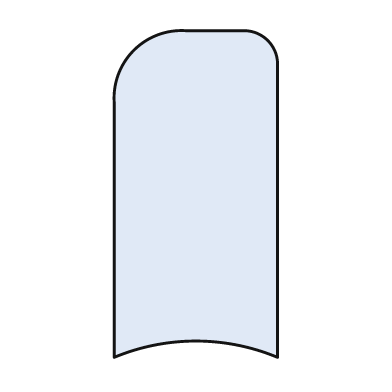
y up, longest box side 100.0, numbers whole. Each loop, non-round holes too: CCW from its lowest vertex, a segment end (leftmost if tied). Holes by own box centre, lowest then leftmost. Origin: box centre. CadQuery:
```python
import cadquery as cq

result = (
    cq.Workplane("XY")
    .moveTo(-25.0, -50.0)
    .threePointArc((0.0, -45.0), (25.0, -50.0))
    .lineTo(25.0, 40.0)
    .threePointArc((22.0, 47.0), (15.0, 50.0))
    .lineTo(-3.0, 50.0)
    .threePointArc((-19.0, 44.0), (-25.0, 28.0))
    .close()
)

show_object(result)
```